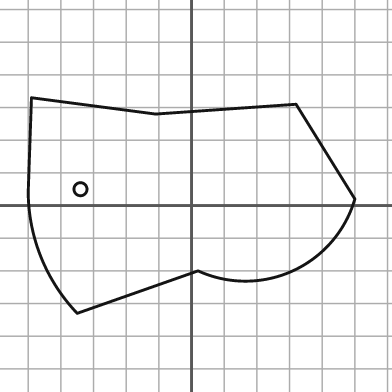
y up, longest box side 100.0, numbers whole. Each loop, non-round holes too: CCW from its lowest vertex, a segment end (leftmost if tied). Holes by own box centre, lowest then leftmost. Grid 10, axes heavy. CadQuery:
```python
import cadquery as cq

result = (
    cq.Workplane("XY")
    .moveTo(-35.0, -33.0)
    .lineTo(2.0, -20.0)
    .threePointArc((31.0, -20.0), (50.0, 2.0))
    .lineTo(32.0, 31.0)
    .lineTo(-11.0, 28.0)
    .lineTo(-49.0, 33.0)
    .lineTo(-50.0, 4.0)
    .threePointArc((-46.0, -16.0), (-35.0, -33.0))
    .close()
    .moveTo(-34.0, 5.0)
    .circle(2.0)
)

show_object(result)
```